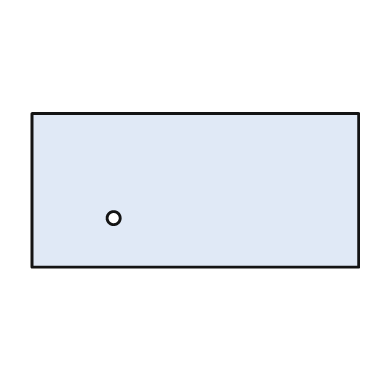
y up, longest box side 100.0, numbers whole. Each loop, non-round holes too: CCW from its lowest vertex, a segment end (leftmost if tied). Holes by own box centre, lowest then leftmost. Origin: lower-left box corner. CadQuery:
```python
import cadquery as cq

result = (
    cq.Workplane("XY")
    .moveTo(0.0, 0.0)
    .lineTo(100.0, 0.0)
    .lineTo(100.0, 47.0)
    .lineTo(0.0, 47.0)
    .close()
    .moveTo(25.0, 15.0)
    .circle(2.0)
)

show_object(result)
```